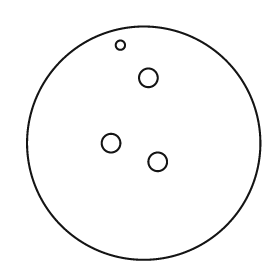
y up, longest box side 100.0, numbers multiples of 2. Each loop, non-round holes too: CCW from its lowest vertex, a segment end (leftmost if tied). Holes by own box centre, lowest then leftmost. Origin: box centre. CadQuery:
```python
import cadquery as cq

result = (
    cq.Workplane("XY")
    .moveTo(0.0, 0.0)
    .circle(50.0)
    .moveTo(6.0, -8.0)
    .circle(4.0)
    .moveTo(-14.0, 0.0)
    .circle(4.0)
    .moveTo(2.0, 28.0)
    .circle(4.0)
    .moveTo(-10.0, 42.0)
    .circle(2.0)
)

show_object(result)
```